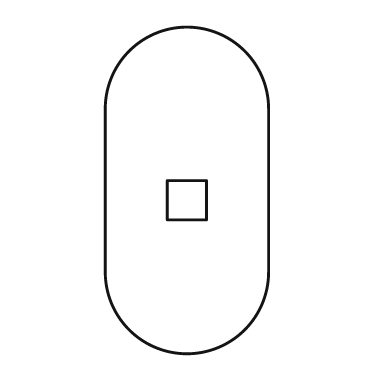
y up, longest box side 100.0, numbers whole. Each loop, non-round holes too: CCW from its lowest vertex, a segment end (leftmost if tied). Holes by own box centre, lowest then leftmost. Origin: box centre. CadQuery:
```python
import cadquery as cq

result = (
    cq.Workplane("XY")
    .moveTo(-25.0, -25.0)
    .threePointArc((0.0, -50.0), (25.0, -25.0))
    .lineTo(25.0, 25.0)
    .threePointArc((0.0, 50.0), (-25.0, 25.0))
    .close()
    .moveTo(-6.0, -9.0)
    .lineTo(6.0, -9.0)
    .lineTo(6.0, 3.0)
    .lineTo(-6.0, 3.0)
    .close()
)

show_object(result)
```